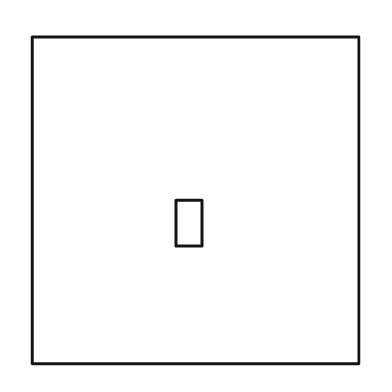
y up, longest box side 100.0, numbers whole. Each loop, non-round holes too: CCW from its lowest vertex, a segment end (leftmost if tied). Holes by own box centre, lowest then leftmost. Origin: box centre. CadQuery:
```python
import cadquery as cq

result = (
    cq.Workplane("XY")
    .moveTo(-50.0, -50.0)
    .lineTo(50.0, -50.0)
    .lineTo(50.0, 50.0)
    .lineTo(-50.0, 50.0)
    .close()
    .moveTo(-6.0, -14.0)
    .lineTo(2.0, -14.0)
    .lineTo(2.0, 0.0)
    .lineTo(-6.0, 0.0)
    .close()
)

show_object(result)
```